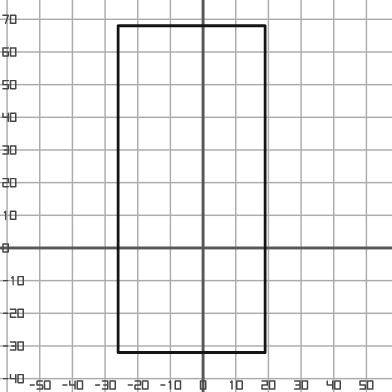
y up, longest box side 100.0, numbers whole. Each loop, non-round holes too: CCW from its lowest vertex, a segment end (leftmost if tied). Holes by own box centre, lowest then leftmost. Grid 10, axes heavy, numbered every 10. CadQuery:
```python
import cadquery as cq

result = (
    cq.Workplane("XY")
    .moveTo(-26.0, -32.0)
    .lineTo(19.0, -32.0)
    .lineTo(19.0, 68.0)
    .lineTo(-26.0, 68.0)
    .close()
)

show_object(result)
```